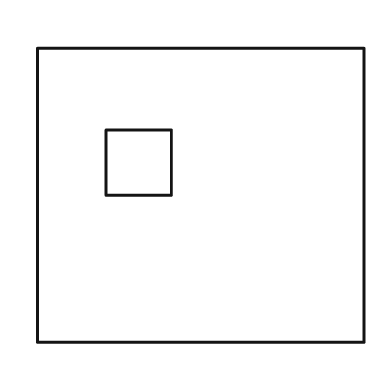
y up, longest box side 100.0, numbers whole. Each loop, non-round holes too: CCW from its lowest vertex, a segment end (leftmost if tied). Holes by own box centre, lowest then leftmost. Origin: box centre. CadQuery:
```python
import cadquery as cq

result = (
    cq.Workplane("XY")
    .moveTo(-50.0, -45.0)
    .lineTo(50.0, -45.0)
    .lineTo(50.0, 45.0)
    .lineTo(-50.0, 45.0)
    .close()
    .moveTo(-29.0, 0.0)
    .lineTo(-9.0, 0.0)
    .lineTo(-9.0, 20.0)
    .lineTo(-29.0, 20.0)
    .close()
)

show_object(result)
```